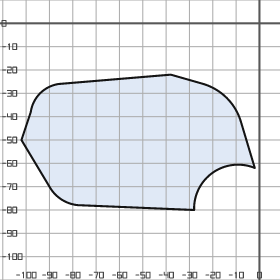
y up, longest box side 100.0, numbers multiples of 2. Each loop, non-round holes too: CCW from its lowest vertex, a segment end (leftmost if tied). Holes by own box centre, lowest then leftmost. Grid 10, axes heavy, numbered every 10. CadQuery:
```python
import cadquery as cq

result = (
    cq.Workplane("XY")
    .moveTo(-28.0, -80.0)
    .threePointArc((-20.0, -64.0), (-2.0, -62.0))
    .lineTo(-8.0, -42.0)
    .threePointArc((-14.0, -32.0), (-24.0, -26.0))
    .lineTo(-38.0, -22.0)
    .lineTo(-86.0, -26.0)
    .threePointArc((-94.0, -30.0), (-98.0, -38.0))
    .lineTo(-102.0, -50.0)
    .lineTo(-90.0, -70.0)
    .threePointArc((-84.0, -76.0), (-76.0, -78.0))
    .close()
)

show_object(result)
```